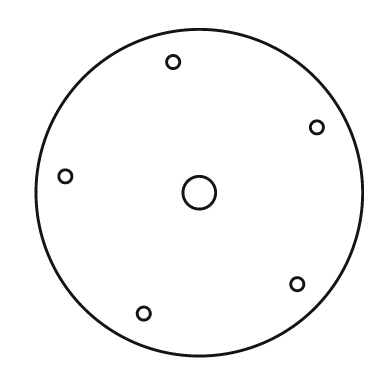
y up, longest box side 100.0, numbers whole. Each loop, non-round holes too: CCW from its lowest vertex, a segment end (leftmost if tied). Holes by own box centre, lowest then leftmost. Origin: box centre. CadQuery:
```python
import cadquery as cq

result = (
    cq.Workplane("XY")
    .moveTo(0.0, 0.0)
    .circle(50.0)
    .moveTo(-17.0, -37.0)
    .circle(2.0)
    .moveTo(30.0, -28.0)
    .circle(2.0)
    .moveTo(0.0, 0.0)
    .circle(5.0)
    .moveTo(-41.0, 5.0)
    .circle(2.0)
    .moveTo(36.0, 20.0)
    .circle(2.0)
    .moveTo(-8.0, 40.0)
    .circle(2.0)
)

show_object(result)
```